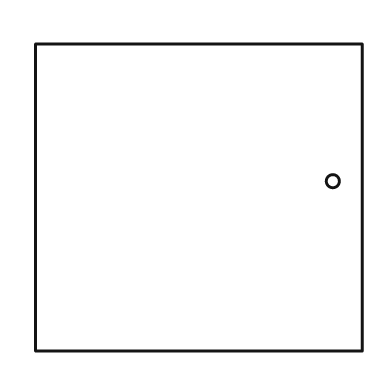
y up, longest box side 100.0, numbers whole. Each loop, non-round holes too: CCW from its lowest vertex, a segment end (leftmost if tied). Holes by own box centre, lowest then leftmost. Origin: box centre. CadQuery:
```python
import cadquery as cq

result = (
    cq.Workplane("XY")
    .moveTo(-50.0, -47.0)
    .lineTo(50.0, -47.0)
    .lineTo(50.0, 47.0)
    .lineTo(-50.0, 47.0)
    .close()
    .moveTo(41.0, 5.0)
    .circle(2.0)
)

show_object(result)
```